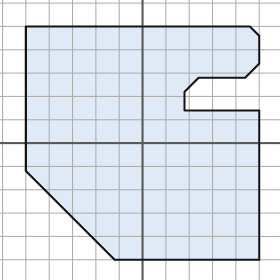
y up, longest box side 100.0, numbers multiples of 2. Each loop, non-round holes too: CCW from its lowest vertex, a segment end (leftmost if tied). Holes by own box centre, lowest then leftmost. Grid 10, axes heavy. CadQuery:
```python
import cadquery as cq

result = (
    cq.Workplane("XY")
    .moveTo(-12.0, -50.0)
    .lineTo(50.0, -50.0)
    .lineTo(50.0, 14.0)
    .lineTo(18.0, 14.0)
    .lineTo(18.0, 22.0)
    .lineTo(24.0, 28.0)
    .lineTo(44.0, 28.0)
    .lineTo(50.0, 34.0)
    .lineTo(50.0, 46.0)
    .lineTo(46.0, 50.0)
    .lineTo(-50.0, 50.0)
    .lineTo(-50.0, -12.0)
    .close()
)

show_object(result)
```